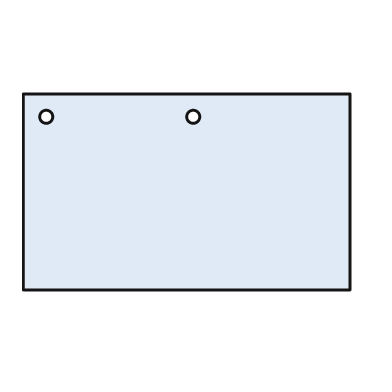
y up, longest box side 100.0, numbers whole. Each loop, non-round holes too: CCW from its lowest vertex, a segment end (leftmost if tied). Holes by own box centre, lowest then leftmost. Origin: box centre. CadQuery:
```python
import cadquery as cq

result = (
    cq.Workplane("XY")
    .moveTo(-50.0, -30.0)
    .lineTo(50.0, -30.0)
    .lineTo(50.0, 30.0)
    .lineTo(-50.0, 30.0)
    .close()
    .moveTo(-43.0, 23.0)
    .circle(2.0)
    .moveTo(2.0, 23.0)
    .circle(2.0)
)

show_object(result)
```